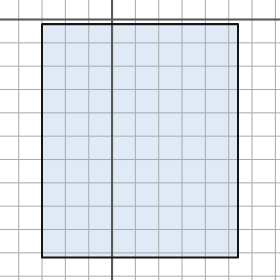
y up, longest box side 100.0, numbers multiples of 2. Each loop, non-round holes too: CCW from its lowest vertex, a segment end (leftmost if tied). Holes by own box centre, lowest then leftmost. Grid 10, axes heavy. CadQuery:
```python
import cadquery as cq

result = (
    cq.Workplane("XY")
    .moveTo(-30.0, -102.0)
    .lineTo(54.0, -102.0)
    .lineTo(54.0, -2.0)
    .lineTo(-30.0, -2.0)
    .close()
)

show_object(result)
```